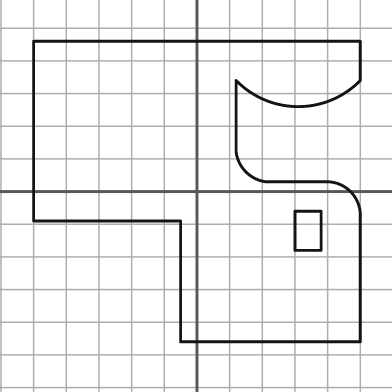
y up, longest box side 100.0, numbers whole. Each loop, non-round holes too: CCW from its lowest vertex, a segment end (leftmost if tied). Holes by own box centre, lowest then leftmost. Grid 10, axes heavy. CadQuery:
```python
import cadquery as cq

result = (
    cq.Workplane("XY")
    .moveTo(-5.0, -46.0)
    .lineTo(50.0, -46.0)
    .lineTo(50.0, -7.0)
    .threePointArc((47.0, 0.0), (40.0, 3.0))
    .lineTo(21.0, 3.0)
    .threePointArc((15.0, 6.0), (12.0, 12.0))
    .lineTo(12.0, 34.0)
    .threePointArc((31.0, 26.0), (50.0, 34.0))
    .lineTo(50.0, 46.0)
    .lineTo(-50.0, 46.0)
    .lineTo(-50.0, -9.0)
    .lineTo(-5.0, -9.0)
    .close()
    .moveTo(30.0, -18.0)
    .lineTo(38.0, -18.0)
    .lineTo(38.0, -6.0)
    .lineTo(30.0, -6.0)
    .close()
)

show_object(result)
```